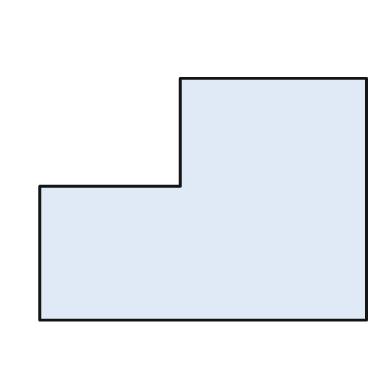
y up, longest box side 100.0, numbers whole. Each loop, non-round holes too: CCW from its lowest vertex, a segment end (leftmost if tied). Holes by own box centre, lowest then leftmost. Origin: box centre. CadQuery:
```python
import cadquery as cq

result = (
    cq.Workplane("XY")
    .moveTo(-50.0, -37.0)
    .lineTo(50.0, -37.0)
    .lineTo(50.0, 37.0)
    .lineTo(-7.0, 37.0)
    .lineTo(-7.0, 4.0)
    .lineTo(-50.0, 4.0)
    .close()
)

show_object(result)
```